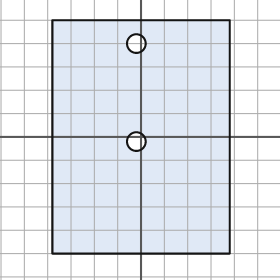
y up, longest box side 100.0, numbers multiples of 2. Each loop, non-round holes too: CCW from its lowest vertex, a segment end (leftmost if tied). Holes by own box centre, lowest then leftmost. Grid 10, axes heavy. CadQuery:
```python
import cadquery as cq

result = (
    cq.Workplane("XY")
    .moveTo(-38.0, -50.0)
    .lineTo(38.0, -50.0)
    .lineTo(38.0, 50.0)
    .lineTo(-38.0, 50.0)
    .close()
    .moveTo(-2.0, -2.0)
    .circle(4.0)
    .moveTo(-2.0, 40.0)
    .circle(4.0)
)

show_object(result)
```